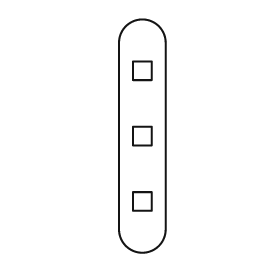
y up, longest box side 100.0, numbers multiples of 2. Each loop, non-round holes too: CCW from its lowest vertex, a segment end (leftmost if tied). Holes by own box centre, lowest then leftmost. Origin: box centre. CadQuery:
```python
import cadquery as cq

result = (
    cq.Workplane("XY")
    .moveTo(-10.0, -40.0)
    .threePointArc((0.0, -50.0), (10.0, -40.0))
    .lineTo(10.0, 40.0)
    .threePointArc((0.0, 50.0), (-10.0, 40.0))
    .close()
    .moveTo(-4.0, -32.0)
    .lineTo(4.0, -32.0)
    .lineTo(4.0, -24.0)
    .lineTo(-4.0, -24.0)
    .close()
    .moveTo(-4.0, -4.0)
    .lineTo(4.0, -4.0)
    .lineTo(4.0, 4.0)
    .lineTo(-4.0, 4.0)
    .close()
    .moveTo(-4.0, 24.0)
    .lineTo(4.0, 24.0)
    .lineTo(4.0, 32.0)
    .lineTo(-4.0, 32.0)
    .close()
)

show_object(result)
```